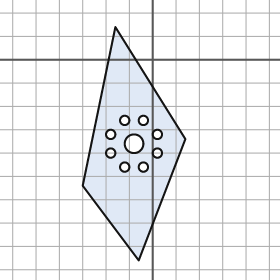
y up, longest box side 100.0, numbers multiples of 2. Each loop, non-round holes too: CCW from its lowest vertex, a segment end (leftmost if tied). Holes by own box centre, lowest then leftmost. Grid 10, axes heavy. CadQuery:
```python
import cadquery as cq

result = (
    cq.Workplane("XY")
    .moveTo(-6.0, -86.0)
    .lineTo(14.0, -34.0)
    .lineTo(-16.0, 14.0)
    .lineTo(-30.0, -54.0)
    .close()
    .moveTo(-12.0, -46.0)
    .circle(2.0)
    .moveTo(-4.0, -46.0)
    .circle(2.0)
    .moveTo(-18.0, -40.0)
    .circle(2.0)
    .moveTo(2.0, -40.0)
    .circle(2.0)
    .moveTo(-8.0, -36.0)
    .circle(4.0)
    .moveTo(-18.0, -32.0)
    .circle(2.0)
    .moveTo(2.0, -32.0)
    .circle(2.0)
    .moveTo(-12.0, -26.0)
    .circle(2.0)
    .moveTo(-4.0, -26.0)
    .circle(2.0)
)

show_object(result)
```